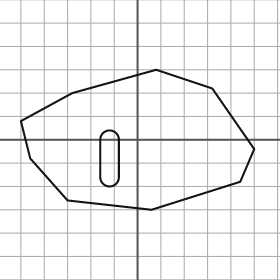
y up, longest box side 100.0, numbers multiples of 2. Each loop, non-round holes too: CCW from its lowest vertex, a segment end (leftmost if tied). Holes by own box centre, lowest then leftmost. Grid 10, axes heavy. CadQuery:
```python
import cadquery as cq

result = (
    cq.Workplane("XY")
    .moveTo(6.0, -30.0)
    .lineTo(44.0, -18.0)
    .lineTo(50.0, -4.0)
    .lineTo(32.0, 22.0)
    .lineTo(8.0, 30.0)
    .lineTo(-28.0, 20.0)
    .lineTo(-50.0, 8.0)
    .lineTo(-46.0, -8.0)
    .lineTo(-30.0, -26.0)
    .close()
    .moveTo(-16.0, -16.0)
    .threePointArc((-12.0, -20.0), (-8.0, -16.0))
    .lineTo(-8.0, 0.0)
    .threePointArc((-12.0, 4.0), (-16.0, 0.0))
    .close()
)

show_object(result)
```